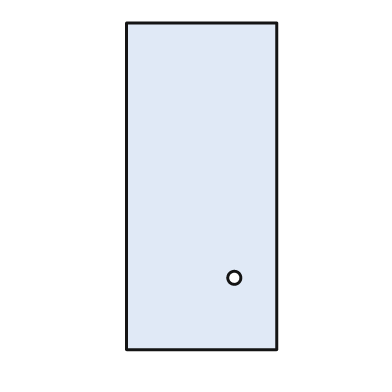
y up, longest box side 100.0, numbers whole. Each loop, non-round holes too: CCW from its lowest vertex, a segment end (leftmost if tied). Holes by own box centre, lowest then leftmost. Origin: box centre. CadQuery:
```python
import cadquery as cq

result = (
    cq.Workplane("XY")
    .moveTo(-23.0, -50.0)
    .lineTo(23.0, -50.0)
    .lineTo(23.0, 50.0)
    .lineTo(-23.0, 50.0)
    .close()
    .moveTo(10.0, -28.0)
    .circle(2.0)
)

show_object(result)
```